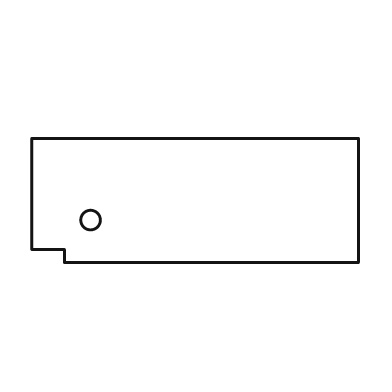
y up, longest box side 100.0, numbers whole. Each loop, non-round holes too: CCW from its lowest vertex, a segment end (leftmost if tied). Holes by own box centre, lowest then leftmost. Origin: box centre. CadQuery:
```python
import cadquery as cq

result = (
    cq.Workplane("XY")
    .moveTo(-40.0, -19.0)
    .lineTo(50.0, -19.0)
    .lineTo(50.0, 19.0)
    .lineTo(-50.0, 19.0)
    .lineTo(-50.0, -15.0)
    .lineTo(-40.0, -15.0)
    .close()
    .moveTo(-32.0, -6.0)
    .circle(3.0)
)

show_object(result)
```